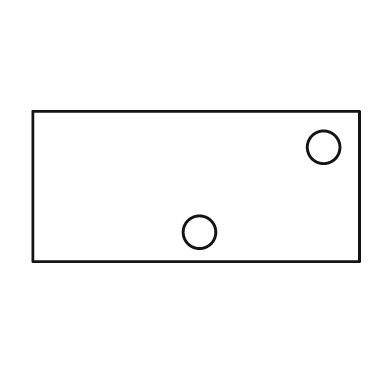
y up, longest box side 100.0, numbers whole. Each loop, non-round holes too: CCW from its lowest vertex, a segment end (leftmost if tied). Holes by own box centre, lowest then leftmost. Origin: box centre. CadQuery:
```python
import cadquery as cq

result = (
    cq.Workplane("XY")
    .moveTo(-50.0, -23.0)
    .lineTo(50.0, -23.0)
    .lineTo(50.0, 23.0)
    .lineTo(-50.0, 23.0)
    .close()
    .moveTo(1.0, -14.0)
    .circle(5.0)
    .moveTo(39.0, 12.0)
    .circle(5.0)
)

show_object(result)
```